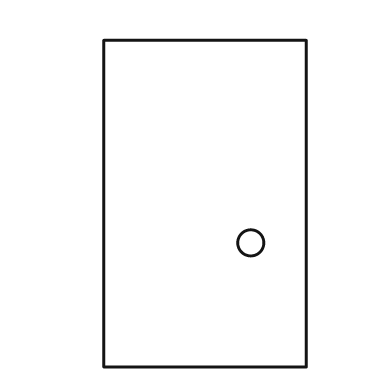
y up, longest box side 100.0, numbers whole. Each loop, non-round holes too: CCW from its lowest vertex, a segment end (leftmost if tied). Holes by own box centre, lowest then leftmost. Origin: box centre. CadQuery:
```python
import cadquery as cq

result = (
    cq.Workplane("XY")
    .moveTo(-31.0, -50.0)
    .lineTo(31.0, -50.0)
    .lineTo(31.0, 50.0)
    .lineTo(-31.0, 50.0)
    .close()
    .moveTo(14.0, -12.0)
    .circle(4.0)
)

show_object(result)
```